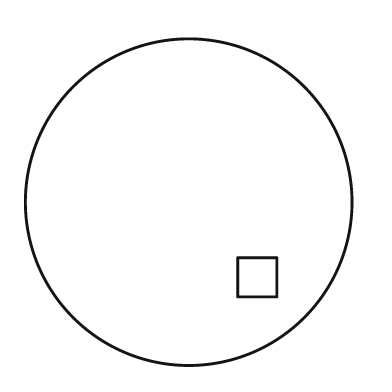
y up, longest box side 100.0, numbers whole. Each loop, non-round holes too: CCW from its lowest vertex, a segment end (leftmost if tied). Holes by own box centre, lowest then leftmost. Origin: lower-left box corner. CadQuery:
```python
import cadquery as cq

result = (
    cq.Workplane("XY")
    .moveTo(50.0, 50.0)
    .circle(50.0)
    .moveTo(65.0, 21.0)
    .lineTo(77.0, 21.0)
    .lineTo(77.0, 33.0)
    .lineTo(65.0, 33.0)
    .close()
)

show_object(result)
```